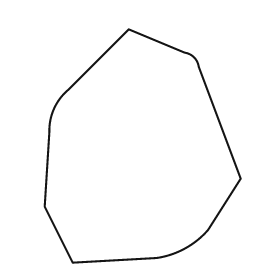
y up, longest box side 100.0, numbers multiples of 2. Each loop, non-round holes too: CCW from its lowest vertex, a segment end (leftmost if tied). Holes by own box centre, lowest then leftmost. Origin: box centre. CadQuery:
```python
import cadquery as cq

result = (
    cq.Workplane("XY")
    .moveTo(-30.0, -50.0)
    .lineTo(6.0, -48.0)
    .threePointArc((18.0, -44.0), (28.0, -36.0))
    .lineTo(42.0, -14.0)
    .lineTo(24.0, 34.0)
    .threePointArc((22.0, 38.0), (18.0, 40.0))
    .lineTo(-6.0, 50.0)
    .lineTo(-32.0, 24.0)
    .threePointArc((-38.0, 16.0), (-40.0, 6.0))
    .lineTo(-42.0, -26.0)
    .close()
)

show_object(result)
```